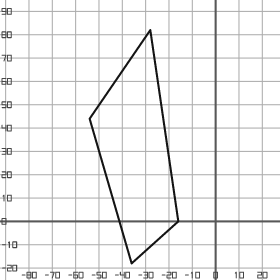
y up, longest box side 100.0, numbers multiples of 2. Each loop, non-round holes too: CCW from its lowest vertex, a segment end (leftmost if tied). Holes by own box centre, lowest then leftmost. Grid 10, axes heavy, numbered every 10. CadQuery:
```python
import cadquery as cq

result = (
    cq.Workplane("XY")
    .moveTo(-36.0, -18.0)
    .lineTo(-16.0, 0.0)
    .lineTo(-28.0, 82.0)
    .lineTo(-54.0, 44.0)
    .close()
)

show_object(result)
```